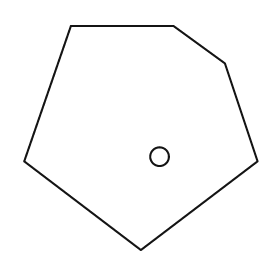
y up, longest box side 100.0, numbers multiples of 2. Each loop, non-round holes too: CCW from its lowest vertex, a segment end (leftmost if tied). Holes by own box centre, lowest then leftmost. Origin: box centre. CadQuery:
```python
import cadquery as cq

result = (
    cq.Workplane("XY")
    .moveTo(0.0, -48.0)
    .lineTo(50.0, -10.0)
    .lineTo(36.0, 32.0)
    .lineTo(14.0, 48.0)
    .lineTo(-30.0, 48.0)
    .lineTo(-50.0, -10.0)
    .close()
    .moveTo(8.0, -8.0)
    .circle(4.0)
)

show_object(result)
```